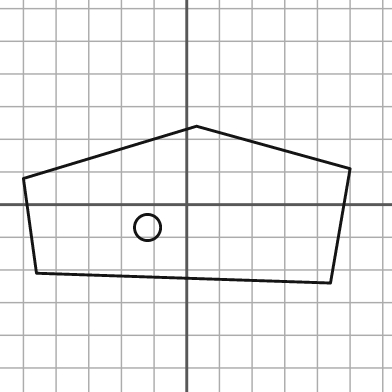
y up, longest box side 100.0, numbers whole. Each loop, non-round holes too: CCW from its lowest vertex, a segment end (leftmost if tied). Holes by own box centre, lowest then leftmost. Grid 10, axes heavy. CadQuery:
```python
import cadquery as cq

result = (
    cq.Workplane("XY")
    .moveTo(44.0, -24.0)
    .lineTo(50.0, 11.0)
    .lineTo(3.0, 24.0)
    .lineTo(-50.0, 8.0)
    .lineTo(-46.0, -21.0)
    .close()
    .moveTo(-12.0, -7.0)
    .circle(4.0)
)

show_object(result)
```